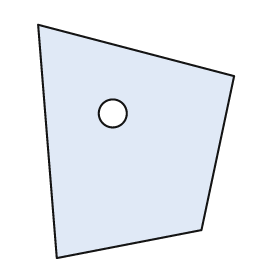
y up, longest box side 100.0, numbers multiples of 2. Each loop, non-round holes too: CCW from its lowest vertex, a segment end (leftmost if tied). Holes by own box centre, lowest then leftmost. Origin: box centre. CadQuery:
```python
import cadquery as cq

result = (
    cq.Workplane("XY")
    .moveTo(-34.0, -50.0)
    .lineTo(28.0, -38.0)
    .lineTo(42.0, 28.0)
    .lineTo(-42.0, 50.0)
    .close()
    .moveTo(-10.0, 12.0)
    .circle(6.0)
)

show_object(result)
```